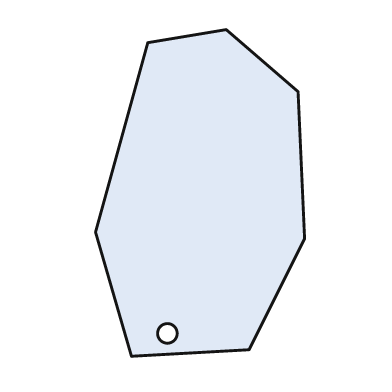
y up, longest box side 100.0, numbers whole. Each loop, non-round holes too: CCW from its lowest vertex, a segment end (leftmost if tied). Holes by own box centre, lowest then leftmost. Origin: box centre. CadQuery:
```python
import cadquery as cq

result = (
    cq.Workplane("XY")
    .moveTo(-21.0, -50.0)
    .lineTo(15.0, -48.0)
    .lineTo(32.0, -14.0)
    .lineTo(30.0, 31.0)
    .lineTo(8.0, 50.0)
    .lineTo(-16.0, 46.0)
    .lineTo(-32.0, -12.0)
    .close()
    .moveTo(-10.0, -43.0)
    .circle(3.0)
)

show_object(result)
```